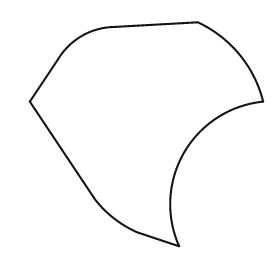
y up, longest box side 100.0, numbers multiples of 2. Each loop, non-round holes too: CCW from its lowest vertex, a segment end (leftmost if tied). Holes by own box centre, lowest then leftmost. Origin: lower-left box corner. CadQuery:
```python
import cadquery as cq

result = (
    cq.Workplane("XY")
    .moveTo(64.0, 0.0)
    .threePointArc((66.0, 40.0), (100.0, 62.0))
    .threePointArc((90.0, 82.0), (72.0, 96.0))
    .lineTo(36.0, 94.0)
    .threePointArc((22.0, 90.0), (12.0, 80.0))
    .lineTo(0.0, 62.0)
    .lineTo(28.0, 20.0)
    .threePointArc((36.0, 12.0), (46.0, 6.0))
    .close()
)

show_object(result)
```